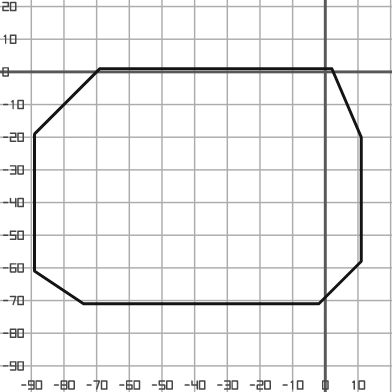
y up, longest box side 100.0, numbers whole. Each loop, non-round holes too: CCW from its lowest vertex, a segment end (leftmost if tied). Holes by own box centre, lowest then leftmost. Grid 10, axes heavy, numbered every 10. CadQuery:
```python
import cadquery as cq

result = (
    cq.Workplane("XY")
    .moveTo(-74.0, -71.0)
    .lineTo(-2.0, -71.0)
    .lineTo(11.0, -58.0)
    .lineTo(11.0, -20.0)
    .lineTo(2.0, 1.0)
    .lineTo(-69.0, 1.0)
    .lineTo(-89.0, -19.0)
    .lineTo(-89.0, -61.0)
    .close()
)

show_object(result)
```